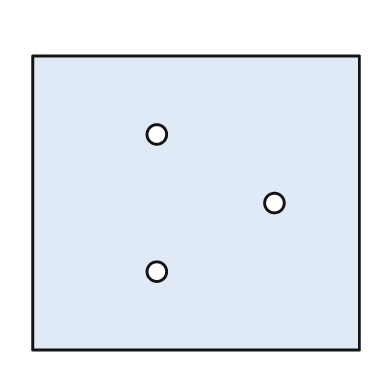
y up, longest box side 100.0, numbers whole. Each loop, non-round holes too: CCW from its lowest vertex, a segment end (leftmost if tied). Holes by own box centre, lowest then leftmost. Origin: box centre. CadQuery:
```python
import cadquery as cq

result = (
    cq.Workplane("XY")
    .moveTo(-50.0, -45.0)
    .lineTo(50.0, -45.0)
    .lineTo(50.0, 45.0)
    .lineTo(-50.0, 45.0)
    .close()
    .moveTo(-12.0, -21.0)
    .circle(3.0)
    .moveTo(24.0, 0.0)
    .circle(3.0)
    .moveTo(-12.0, 21.0)
    .circle(3.0)
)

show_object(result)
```